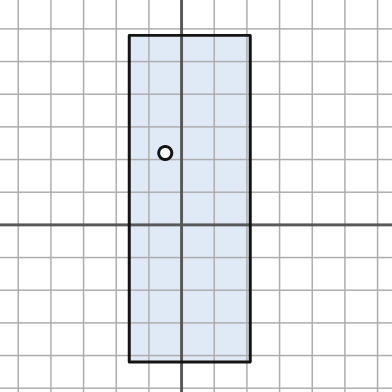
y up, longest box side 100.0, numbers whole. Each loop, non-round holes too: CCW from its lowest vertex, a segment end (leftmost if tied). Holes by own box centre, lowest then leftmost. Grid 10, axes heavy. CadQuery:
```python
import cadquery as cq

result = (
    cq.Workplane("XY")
    .moveTo(-16.0, -42.0)
    .lineTo(21.0, -42.0)
    .lineTo(21.0, 58.0)
    .lineTo(-16.0, 58.0)
    .close()
    .moveTo(-5.0, 22.0)
    .circle(2.0)
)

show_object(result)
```